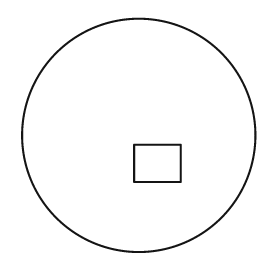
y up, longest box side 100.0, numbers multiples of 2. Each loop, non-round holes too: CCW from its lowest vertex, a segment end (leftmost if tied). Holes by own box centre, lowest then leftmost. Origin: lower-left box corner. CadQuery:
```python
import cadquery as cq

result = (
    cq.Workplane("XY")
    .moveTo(50.0, 50.0)
    .circle(50.0)
    .moveTo(48.0, 30.0)
    .lineTo(68.0, 30.0)
    .lineTo(68.0, 46.0)
    .lineTo(48.0, 46.0)
    .close()
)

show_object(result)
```